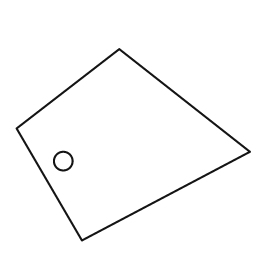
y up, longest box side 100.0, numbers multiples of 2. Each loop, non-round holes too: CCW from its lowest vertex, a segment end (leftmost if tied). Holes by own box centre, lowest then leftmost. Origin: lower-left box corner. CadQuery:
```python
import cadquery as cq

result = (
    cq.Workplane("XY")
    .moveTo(28.0, 0.0)
    .lineTo(100.0, 38.0)
    .lineTo(44.0, 82.0)
    .lineTo(0.0, 48.0)
    .close()
    .moveTo(20.0, 34.0)
    .circle(4.0)
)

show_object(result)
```